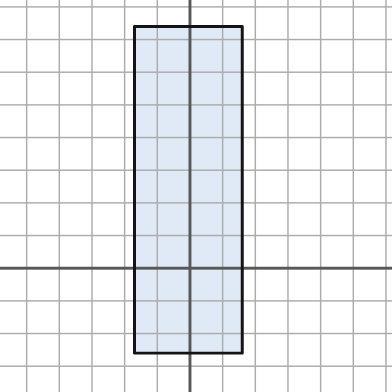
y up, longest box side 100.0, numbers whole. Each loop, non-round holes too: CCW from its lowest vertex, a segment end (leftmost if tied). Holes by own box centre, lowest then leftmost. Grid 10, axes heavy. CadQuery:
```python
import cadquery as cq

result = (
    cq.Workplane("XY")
    .moveTo(-17.0, -26.0)
    .lineTo(16.0, -26.0)
    .lineTo(16.0, 74.0)
    .lineTo(-17.0, 74.0)
    .close()
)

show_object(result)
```